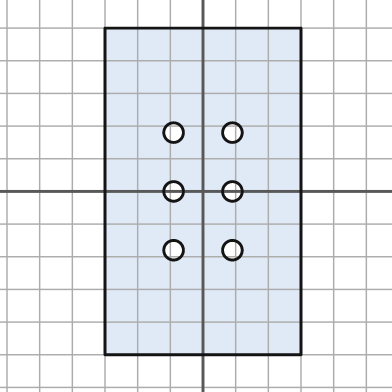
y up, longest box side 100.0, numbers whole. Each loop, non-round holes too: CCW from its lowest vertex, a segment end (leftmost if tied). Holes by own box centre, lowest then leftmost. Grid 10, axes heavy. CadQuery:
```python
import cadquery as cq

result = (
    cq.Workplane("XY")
    .moveTo(-30.0, -50.0)
    .lineTo(30.0, -50.0)
    .lineTo(30.0, 50.0)
    .lineTo(-30.0, 50.0)
    .close()
    .moveTo(-9.0, -18.0)
    .circle(3.0)
    .moveTo(9.0, -18.0)
    .circle(3.0)
    .moveTo(-9.0, 0.0)
    .circle(3.0)
    .moveTo(9.0, 0.0)
    .circle(3.0)
    .moveTo(-9.0, 18.0)
    .circle(3.0)
    .moveTo(9.0, 18.0)
    .circle(3.0)
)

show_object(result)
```